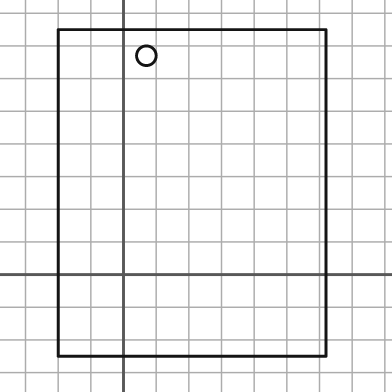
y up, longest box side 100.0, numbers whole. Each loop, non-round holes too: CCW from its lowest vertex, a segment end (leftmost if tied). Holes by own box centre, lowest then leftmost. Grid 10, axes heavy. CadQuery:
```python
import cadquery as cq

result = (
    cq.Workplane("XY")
    .moveTo(-20.0, -25.0)
    .lineTo(62.0, -25.0)
    .lineTo(62.0, 75.0)
    .lineTo(-20.0, 75.0)
    .close()
    .moveTo(7.0, 67.0)
    .circle(3.0)
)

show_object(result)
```